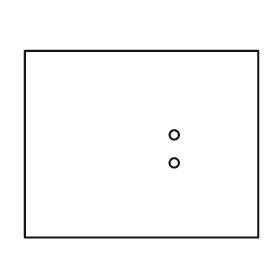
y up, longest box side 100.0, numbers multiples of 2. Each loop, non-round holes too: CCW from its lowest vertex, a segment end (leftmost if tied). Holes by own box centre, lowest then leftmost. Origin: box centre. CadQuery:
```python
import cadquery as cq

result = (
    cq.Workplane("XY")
    .moveTo(-50.0, -40.0)
    .lineTo(50.0, -40.0)
    .lineTo(50.0, 40.0)
    .lineTo(-50.0, 40.0)
    .close()
    .moveTo(14.0, -8.0)
    .circle(2.0)
    .moveTo(14.0, 4.0)
    .circle(2.0)
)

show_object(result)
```